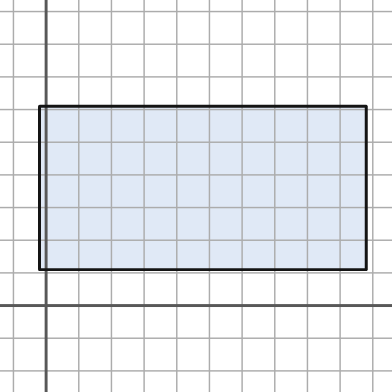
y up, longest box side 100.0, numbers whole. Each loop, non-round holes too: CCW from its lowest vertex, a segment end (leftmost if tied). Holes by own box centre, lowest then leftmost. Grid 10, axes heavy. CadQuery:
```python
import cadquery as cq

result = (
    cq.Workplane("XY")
    .moveTo(-2.0, 11.0)
    .lineTo(98.0, 11.0)
    .lineTo(98.0, 61.0)
    .lineTo(-2.0, 61.0)
    .close()
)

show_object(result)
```